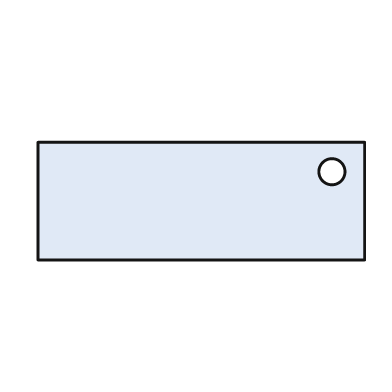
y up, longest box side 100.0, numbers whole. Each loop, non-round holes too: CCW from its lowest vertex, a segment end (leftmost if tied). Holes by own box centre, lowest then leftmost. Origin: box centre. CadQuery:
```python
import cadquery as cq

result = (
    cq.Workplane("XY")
    .moveTo(-50.0, -18.0)
    .lineTo(50.0, -18.0)
    .lineTo(50.0, 18.0)
    .lineTo(-50.0, 18.0)
    .close()
    .moveTo(40.0, 9.0)
    .circle(4.0)
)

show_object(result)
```